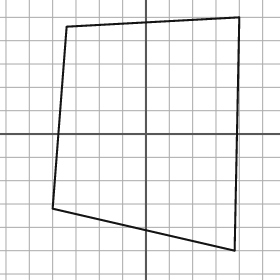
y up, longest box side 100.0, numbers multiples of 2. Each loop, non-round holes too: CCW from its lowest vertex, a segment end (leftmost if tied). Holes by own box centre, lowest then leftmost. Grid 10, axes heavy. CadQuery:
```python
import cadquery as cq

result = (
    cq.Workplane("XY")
    .moveTo(38.0, -50.0)
    .lineTo(40.0, 50.0)
    .lineTo(-34.0, 46.0)
    .lineTo(-40.0, -32.0)
    .close()
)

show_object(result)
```